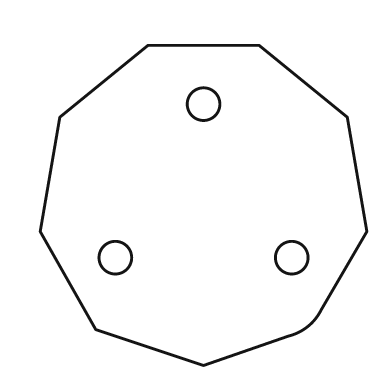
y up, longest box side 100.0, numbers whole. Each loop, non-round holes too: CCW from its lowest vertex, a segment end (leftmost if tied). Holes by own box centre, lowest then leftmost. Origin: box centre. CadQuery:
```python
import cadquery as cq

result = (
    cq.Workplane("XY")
    .moveTo(0.0, -49.0)
    .lineTo(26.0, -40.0)
    .threePointArc((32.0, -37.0), (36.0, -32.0))
    .lineTo(50.0, -8.0)
    .lineTo(44.0, 27.0)
    .lineTo(17.0, 49.0)
    .lineTo(-17.0, 49.0)
    .lineTo(-44.0, 27.0)
    .lineTo(-50.0, -8.0)
    .lineTo(-33.0, -38.0)
    .close()
    .moveTo(-27.0, -16.0)
    .circle(5.0)
    .moveTo(27.0, -16.0)
    .circle(5.0)
    .moveTo(0.0, 31.0)
    .circle(5.0)
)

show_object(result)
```